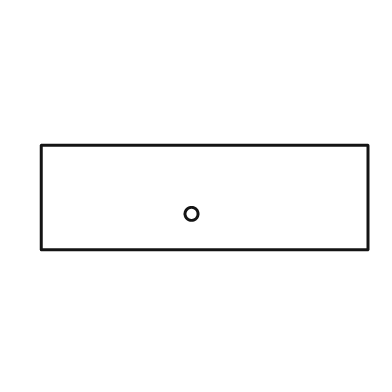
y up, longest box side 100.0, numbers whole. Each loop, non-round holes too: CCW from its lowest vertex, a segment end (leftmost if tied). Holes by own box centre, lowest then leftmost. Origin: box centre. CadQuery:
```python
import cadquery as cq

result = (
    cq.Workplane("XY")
    .moveTo(-50.0, -16.0)
    .lineTo(50.0, -16.0)
    .lineTo(50.0, 16.0)
    .lineTo(-50.0, 16.0)
    .close()
    .moveTo(-4.0, -5.0)
    .circle(2.0)
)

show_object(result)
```